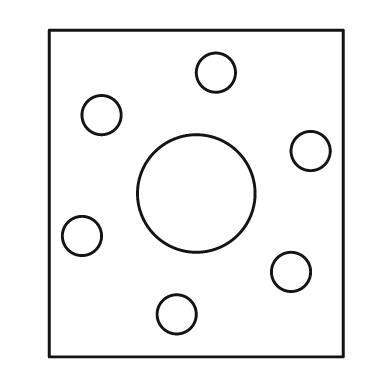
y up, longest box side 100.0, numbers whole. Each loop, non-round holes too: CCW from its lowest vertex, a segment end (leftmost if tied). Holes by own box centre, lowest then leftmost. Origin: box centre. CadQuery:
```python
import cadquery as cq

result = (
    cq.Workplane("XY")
    .moveTo(-45.0, -50.0)
    .lineTo(45.0, -50.0)
    .lineTo(45.0, 50.0)
    .lineTo(-45.0, 50.0)
    .close()
    .moveTo(-6.0, -37.0)
    .circle(6.0)
    .moveTo(29.0, -24.0)
    .circle(6.0)
    .moveTo(-35.0, -13.0)
    .circle(6.0)
    .moveTo(0.0, 0.0)
    .circle(18.0)
    .moveTo(35.0, 13.0)
    .circle(6.0)
    .moveTo(-29.0, 24.0)
    .circle(6.0)
    .moveTo(6.0, 37.0)
    .circle(6.0)
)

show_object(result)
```